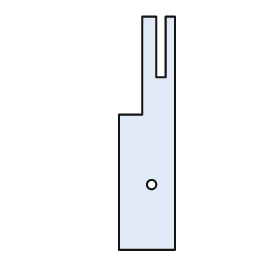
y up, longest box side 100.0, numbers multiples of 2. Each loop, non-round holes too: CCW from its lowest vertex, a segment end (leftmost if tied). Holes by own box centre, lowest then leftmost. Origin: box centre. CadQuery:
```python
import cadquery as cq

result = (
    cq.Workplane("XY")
    .moveTo(-12.0, -50.0)
    .lineTo(12.0, -50.0)
    .lineTo(12.0, 50.0)
    .lineTo(8.0, 50.0)
    .lineTo(8.0, 24.0)
    .lineTo(4.0, 24.0)
    .lineTo(4.0, 50.0)
    .lineTo(-2.0, 50.0)
    .lineTo(-2.0, 8.0)
    .lineTo(-12.0, 8.0)
    .close()
    .moveTo(2.0, -22.0)
    .circle(2.0)
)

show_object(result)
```